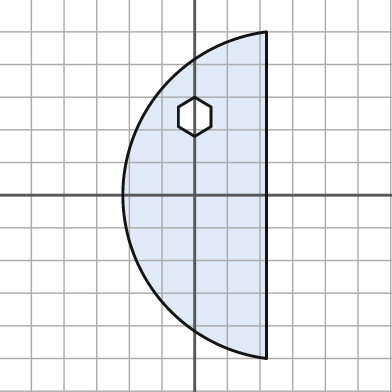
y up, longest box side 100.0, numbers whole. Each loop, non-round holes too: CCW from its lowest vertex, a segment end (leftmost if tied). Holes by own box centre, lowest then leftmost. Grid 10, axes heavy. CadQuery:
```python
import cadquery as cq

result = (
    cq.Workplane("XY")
    .moveTo(22.0, -50.0)
    .lineTo(22.0, 50.0)
    .threePointArc((-22.0, 0.0), (22.0, -50.0))
    .close()
    .moveTo(0.0, 18.0)
    .lineTo(5.0, 21.0)
    .lineTo(5.0, 27.0)
    .lineTo(0.0, 30.0)
    .lineTo(-5.0, 27.0)
    .lineTo(-5.0, 21.0)
    .close()
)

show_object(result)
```